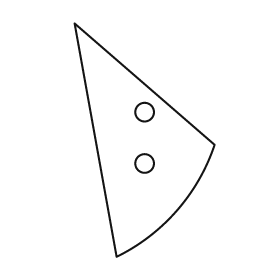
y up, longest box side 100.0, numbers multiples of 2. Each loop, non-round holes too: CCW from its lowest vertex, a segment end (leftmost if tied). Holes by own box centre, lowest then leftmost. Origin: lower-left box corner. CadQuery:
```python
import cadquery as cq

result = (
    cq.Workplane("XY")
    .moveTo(18.0, 0.0)
    .threePointArc((44.0, 20.0), (60.0, 48.0))
    .lineTo(0.0, 100.0)
    .close()
    .moveTo(30.0, 40.0)
    .circle(4.0)
    .moveTo(30.0, 62.0)
    .circle(4.0)
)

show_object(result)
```